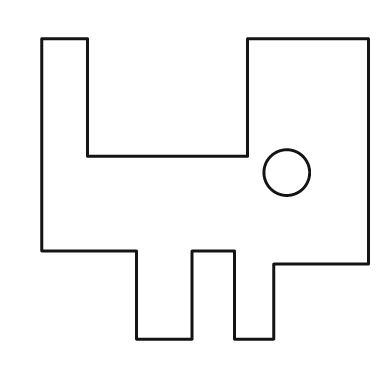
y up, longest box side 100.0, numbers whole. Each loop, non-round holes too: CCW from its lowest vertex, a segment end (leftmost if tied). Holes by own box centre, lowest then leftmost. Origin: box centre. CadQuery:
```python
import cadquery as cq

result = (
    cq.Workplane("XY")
    .moveTo(-21.0, -46.0)
    .lineTo(-4.0, -46.0)
    .lineTo(-4.0, -19.0)
    .lineTo(9.0, -19.0)
    .lineTo(9.0, -46.0)
    .lineTo(21.0, -46.0)
    .lineTo(21.0, -23.0)
    .lineTo(50.0, -23.0)
    .lineTo(50.0, 46.0)
    .lineTo(13.0, 46.0)
    .lineTo(13.0, 10.0)
    .lineTo(-36.0, 10.0)
    .lineTo(-36.0, 46.0)
    .lineTo(-50.0, 46.0)
    .lineTo(-50.0, -19.0)
    .lineTo(-21.0, -19.0)
    .close()
    .moveTo(25.0, 5.0)
    .circle(7.0)
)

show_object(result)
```